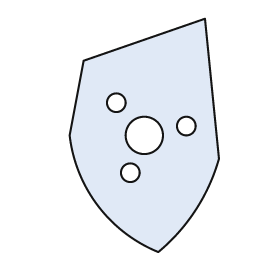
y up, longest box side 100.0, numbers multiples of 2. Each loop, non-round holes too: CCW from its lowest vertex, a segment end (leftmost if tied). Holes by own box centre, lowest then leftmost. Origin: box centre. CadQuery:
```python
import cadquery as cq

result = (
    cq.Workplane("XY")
    .moveTo(6.0, -50.0)
    .threePointArc((22.0, -32.0), (32.0, -10.0))
    .lineTo(26.0, 50.0)
    .lineTo(-26.0, 32.0)
    .lineTo(-32.0, 0.0)
    .threePointArc((-20.0, -30.0), (6.0, -50.0))
    .close()
    .moveTo(-6.0, -16.0)
    .circle(4.0)
    .moveTo(0.0, 0.0)
    .circle(8.0)
    .moveTo(18.0, 4.0)
    .circle(4.0)
    .moveTo(-12.0, 14.0)
    .circle(4.0)
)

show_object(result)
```